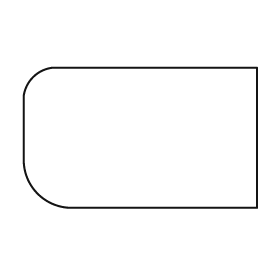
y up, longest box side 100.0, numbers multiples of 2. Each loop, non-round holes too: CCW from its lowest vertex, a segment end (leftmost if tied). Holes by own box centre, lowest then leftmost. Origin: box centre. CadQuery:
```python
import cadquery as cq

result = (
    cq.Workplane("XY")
    .moveTo(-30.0, -30.0)
    .lineTo(50.0, -30.0)
    .lineTo(50.0, 30.0)
    .lineTo(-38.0, 30.0)
    .threePointArc((-46.0, 26.0), (-50.0, 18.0))
    .lineTo(-50.0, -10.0)
    .threePointArc((-44.0, -24.0), (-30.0, -30.0))
    .close()
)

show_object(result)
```